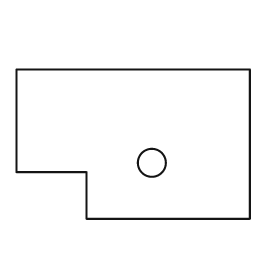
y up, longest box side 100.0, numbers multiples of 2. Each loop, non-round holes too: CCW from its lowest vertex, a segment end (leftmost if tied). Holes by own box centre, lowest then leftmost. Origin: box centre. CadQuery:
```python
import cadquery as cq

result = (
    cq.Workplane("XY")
    .moveTo(-20.0, -32.0)
    .lineTo(50.0, -32.0)
    .lineTo(50.0, 32.0)
    .lineTo(-50.0, 32.0)
    .lineTo(-50.0, -12.0)
    .lineTo(-20.0, -12.0)
    .close()
    .moveTo(8.0, -8.0)
    .circle(6.0)
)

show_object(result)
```